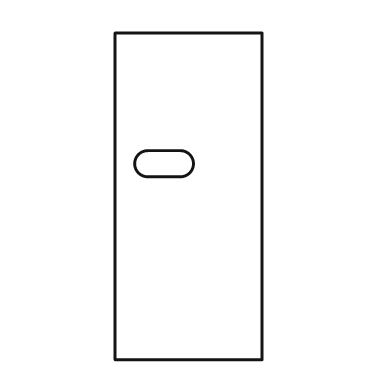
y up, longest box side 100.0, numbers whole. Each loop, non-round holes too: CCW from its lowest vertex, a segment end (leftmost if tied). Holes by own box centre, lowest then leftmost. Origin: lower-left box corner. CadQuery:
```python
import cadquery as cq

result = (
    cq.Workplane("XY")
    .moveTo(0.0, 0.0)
    .lineTo(45.0, 0.0)
    .lineTo(45.0, 100.0)
    .lineTo(0.0, 100.0)
    .close()
    .moveTo(10.0, 56.0)
    .lineTo(20.0, 56.0)
    .threePointArc((24.0, 60.0), (20.0, 64.0))
    .lineTo(10.0, 64.0)
    .threePointArc((6.0, 60.0), (10.0, 56.0))
    .close()
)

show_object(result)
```